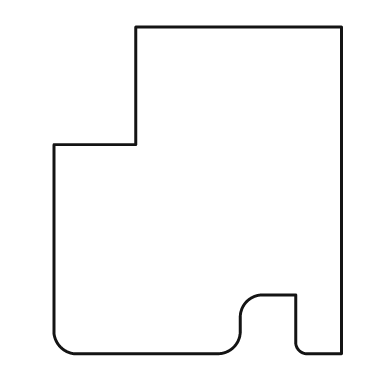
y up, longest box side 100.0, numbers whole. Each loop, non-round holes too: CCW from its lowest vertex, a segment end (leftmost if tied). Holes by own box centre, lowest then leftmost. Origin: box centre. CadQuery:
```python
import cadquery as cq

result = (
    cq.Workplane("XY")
    .moveTo(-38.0, -50.0)
    .lineTo(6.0, -50.0)
    .threePointArc((11.0, -48.0), (13.0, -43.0))
    .lineTo(13.0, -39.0)
    .threePointArc((15.0, -34.0), (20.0, -32.0))
    .lineTo(30.0, -32.0)
    .lineTo(30.0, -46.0)
    .threePointArc((31.0, -49.0), (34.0, -50.0))
    .lineTo(44.0, -50.0)
    .lineTo(44.0, 50.0)
    .lineTo(-19.0, 50.0)
    .lineTo(-19.0, 14.0)
    .lineTo(-44.0, 14.0)
    .lineTo(-44.0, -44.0)
    .threePointArc((-42.0, -48.0), (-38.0, -50.0))
    .close()
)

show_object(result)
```